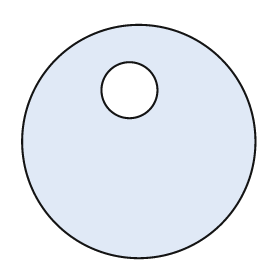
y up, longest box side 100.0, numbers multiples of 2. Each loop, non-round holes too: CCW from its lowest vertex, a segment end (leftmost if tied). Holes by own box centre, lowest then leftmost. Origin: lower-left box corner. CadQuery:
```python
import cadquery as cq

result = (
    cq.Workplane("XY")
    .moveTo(50.0, 50.0)
    .circle(50.0)
    .moveTo(46.0, 72.0)
    .circle(12.0)
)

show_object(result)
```